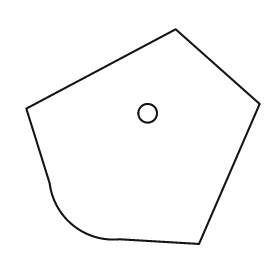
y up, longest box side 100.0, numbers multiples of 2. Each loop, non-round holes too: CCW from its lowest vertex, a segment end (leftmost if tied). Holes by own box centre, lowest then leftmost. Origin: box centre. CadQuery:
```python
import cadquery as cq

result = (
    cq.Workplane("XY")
    .moveTo(24.0, -46.0)
    .lineTo(50.0, 14.0)
    .lineTo(14.0, 46.0)
    .lineTo(-50.0, 12.0)
    .lineTo(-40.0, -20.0)
    .threePointArc((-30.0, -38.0), (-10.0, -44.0))
    .close()
    .moveTo(2.0, 10.0)
    .circle(4.0)
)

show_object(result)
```